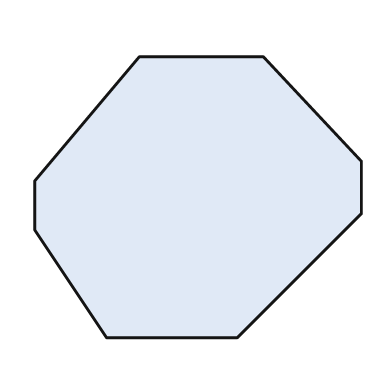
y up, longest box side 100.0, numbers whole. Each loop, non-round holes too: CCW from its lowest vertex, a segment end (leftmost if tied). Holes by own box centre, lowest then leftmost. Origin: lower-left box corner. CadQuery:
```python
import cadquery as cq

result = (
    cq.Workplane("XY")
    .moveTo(22.0, 0.0)
    .lineTo(62.0, 0.0)
    .lineTo(100.0, 38.0)
    .lineTo(100.0, 54.0)
    .lineTo(70.0, 86.0)
    .lineTo(32.0, 86.0)
    .lineTo(0.0, 48.0)
    .lineTo(0.0, 33.0)
    .close()
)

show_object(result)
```